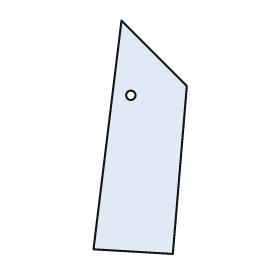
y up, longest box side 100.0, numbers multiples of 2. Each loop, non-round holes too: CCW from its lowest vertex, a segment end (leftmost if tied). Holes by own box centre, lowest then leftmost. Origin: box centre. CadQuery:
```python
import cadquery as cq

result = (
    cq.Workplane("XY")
    .moveTo(14.0, -50.0)
    .lineTo(20.0, 22.0)
    .lineTo(-8.0, 50.0)
    .lineTo(-20.0, -48.0)
    .close()
    .moveTo(-4.0, 18.0)
    .circle(2.0)
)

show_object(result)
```